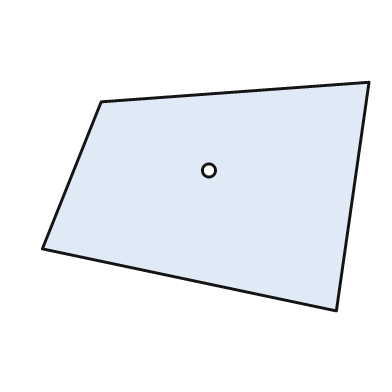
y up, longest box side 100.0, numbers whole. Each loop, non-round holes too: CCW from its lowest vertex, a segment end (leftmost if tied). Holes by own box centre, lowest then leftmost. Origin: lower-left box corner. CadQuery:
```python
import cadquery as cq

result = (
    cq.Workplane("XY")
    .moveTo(90.0, 0.0)
    .lineTo(100.0, 70.0)
    .lineTo(18.0, 64.0)
    .lineTo(0.0, 19.0)
    .close()
    .moveTo(51.0, 43.0)
    .circle(2.0)
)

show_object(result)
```